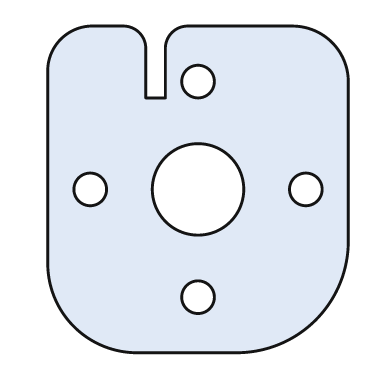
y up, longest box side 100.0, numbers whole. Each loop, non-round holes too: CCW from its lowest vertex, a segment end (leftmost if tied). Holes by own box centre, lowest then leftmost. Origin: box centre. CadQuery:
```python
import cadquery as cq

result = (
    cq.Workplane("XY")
    .moveTo(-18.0, -50.0)
    .lineTo(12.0, -50.0)
    .threePointArc((36.0, -40.0), (46.0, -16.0))
    .lineTo(46.0, 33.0)
    .threePointArc((41.0, 45.0), (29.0, 50.0))
    .lineTo(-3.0, 50.0)
    .threePointArc((-8.0, 48.0), (-10.0, 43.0))
    .lineTo(-10.0, 28.0)
    .lineTo(-16.0, 28.0)
    .lineTo(-16.0, 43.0)
    .threePointArc((-18.0, 48.0), (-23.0, 50.0))
    .lineTo(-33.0, 50.0)
    .threePointArc((-42.0, 46.0), (-46.0, 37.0))
    .lineTo(-46.0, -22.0)
    .threePointArc((-38.0, -42.0), (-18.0, -50.0))
    .close()
    .moveTo(0.0, -33.0)
    .circle(5.0)
    .moveTo(-33.0, 0.0)
    .circle(5.0)
    .moveTo(0.0, 0.0)
    .circle(14.0)
    .moveTo(33.0, 0.0)
    .circle(5.0)
    .moveTo(0.0, 33.0)
    .circle(5.0)
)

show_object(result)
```